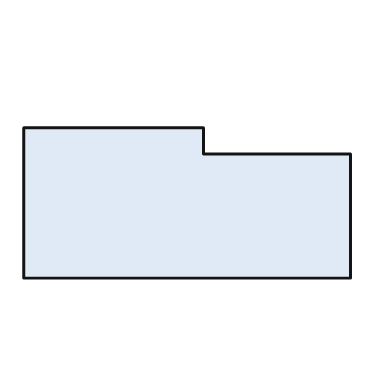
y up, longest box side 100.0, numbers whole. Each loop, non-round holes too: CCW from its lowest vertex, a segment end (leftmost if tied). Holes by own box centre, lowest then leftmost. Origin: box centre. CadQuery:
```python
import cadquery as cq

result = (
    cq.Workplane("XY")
    .moveTo(-50.0, -23.0)
    .lineTo(50.0, -23.0)
    .lineTo(50.0, 15.0)
    .lineTo(5.0, 15.0)
    .lineTo(5.0, 23.0)
    .lineTo(-50.0, 23.0)
    .close()
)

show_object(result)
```